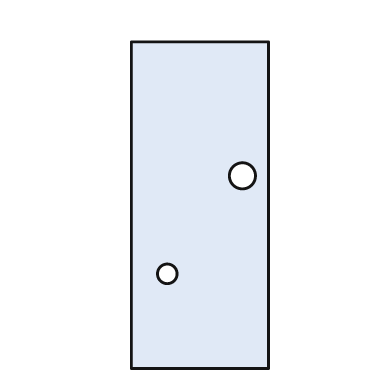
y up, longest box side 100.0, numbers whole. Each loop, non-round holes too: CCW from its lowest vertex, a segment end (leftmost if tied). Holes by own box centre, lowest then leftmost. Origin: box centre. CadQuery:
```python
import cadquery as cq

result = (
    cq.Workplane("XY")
    .moveTo(-21.0, -50.0)
    .lineTo(21.0, -50.0)
    .lineTo(21.0, 50.0)
    .lineTo(-21.0, 50.0)
    .close()
    .moveTo(-10.0, -21.0)
    .circle(3.0)
    .moveTo(13.0, 9.0)
    .circle(4.0)
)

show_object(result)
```